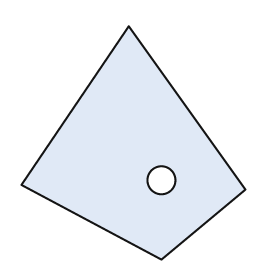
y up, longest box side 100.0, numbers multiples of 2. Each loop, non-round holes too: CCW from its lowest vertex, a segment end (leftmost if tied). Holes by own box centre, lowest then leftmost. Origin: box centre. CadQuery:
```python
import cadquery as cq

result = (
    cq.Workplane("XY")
    .moveTo(12.0, -50.0)
    .lineTo(48.0, -20.0)
    .lineTo(-2.0, 50.0)
    .lineTo(-48.0, -18.0)
    .close()
    .moveTo(12.0, -16.0)
    .circle(6.0)
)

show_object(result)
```